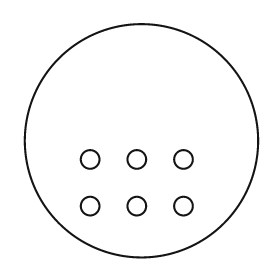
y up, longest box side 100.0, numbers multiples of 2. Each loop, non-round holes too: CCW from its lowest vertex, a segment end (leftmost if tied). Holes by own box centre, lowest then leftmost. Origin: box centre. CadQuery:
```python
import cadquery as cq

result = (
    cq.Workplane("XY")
    .moveTo(0.0, 0.0)
    .circle(50.0)
    .moveTo(-22.0, -28.0)
    .circle(4.0)
    .moveTo(-2.0, -28.0)
    .circle(4.0)
    .moveTo(18.0, -28.0)
    .circle(4.0)
    .moveTo(-22.0, -8.0)
    .circle(4.0)
    .moveTo(-2.0, -8.0)
    .circle(4.0)
    .moveTo(18.0, -8.0)
    .circle(4.0)
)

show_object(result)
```